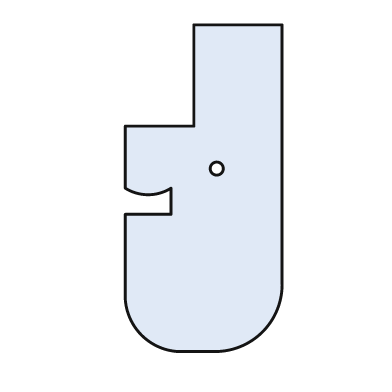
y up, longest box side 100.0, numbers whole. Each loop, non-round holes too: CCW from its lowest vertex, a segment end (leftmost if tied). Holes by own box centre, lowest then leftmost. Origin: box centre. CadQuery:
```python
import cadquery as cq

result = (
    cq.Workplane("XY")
    .moveTo(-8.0, -50.0)
    .lineTo(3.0, -50.0)
    .threePointArc((18.0, -44.0), (24.0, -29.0))
    .lineTo(24.0, 50.0)
    .lineTo(-3.0, 50.0)
    .lineTo(-3.0, 19.0)
    .lineTo(-24.0, 19.0)
    .lineTo(-24.0, 0.0)
    .threePointArc((-17.0, -2.0), (-10.0, 0.0))
    .lineTo(-10.0, -8.0)
    .lineTo(-24.0, -8.0)
    .lineTo(-24.0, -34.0)
    .threePointArc((-19.0, -45.0), (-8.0, -50.0))
    .close()
    .moveTo(4.0, 6.0)
    .circle(2.0)
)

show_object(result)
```